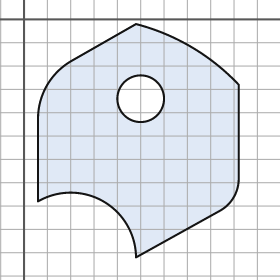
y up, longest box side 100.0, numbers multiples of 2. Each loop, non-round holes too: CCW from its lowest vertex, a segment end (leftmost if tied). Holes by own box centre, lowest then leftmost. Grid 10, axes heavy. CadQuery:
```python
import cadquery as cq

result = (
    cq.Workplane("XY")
    .moveTo(48.0, -102.0)
    .lineTo(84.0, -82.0)
    .threePointArc((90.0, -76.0), (92.0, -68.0))
    .lineTo(92.0, -28.0)
    .threePointArc((72.0, -12.0), (48.0, -2.0))
    .lineTo(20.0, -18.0)
    .threePointArc((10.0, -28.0), (6.0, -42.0))
    .lineTo(6.0, -78.0)
    .threePointArc((34.0, -78.0), (48.0, -102.0))
    .close()
    .moveTo(50.0, -34.0)
    .circle(10.0)
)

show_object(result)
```